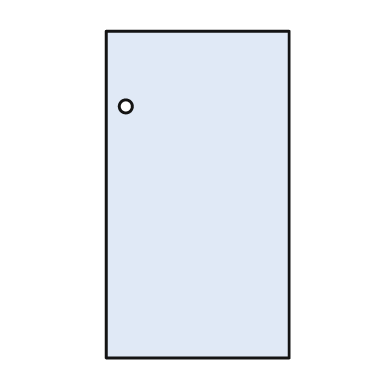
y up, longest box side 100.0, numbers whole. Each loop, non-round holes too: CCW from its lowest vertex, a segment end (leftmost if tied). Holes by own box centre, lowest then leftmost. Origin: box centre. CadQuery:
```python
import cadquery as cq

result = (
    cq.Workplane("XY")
    .moveTo(-28.0, -50.0)
    .lineTo(28.0, -50.0)
    .lineTo(28.0, 50.0)
    .lineTo(-28.0, 50.0)
    .close()
    .moveTo(-22.0, 27.0)
    .circle(2.0)
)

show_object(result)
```